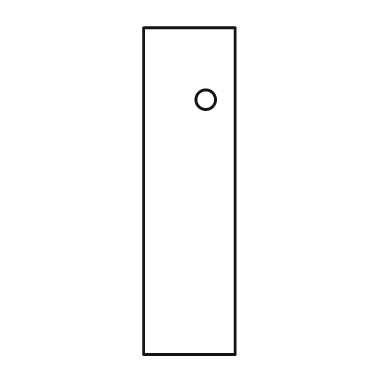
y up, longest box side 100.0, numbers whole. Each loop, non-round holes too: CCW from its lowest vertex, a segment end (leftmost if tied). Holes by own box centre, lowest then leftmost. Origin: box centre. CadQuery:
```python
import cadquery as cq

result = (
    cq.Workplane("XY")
    .moveTo(-14.0, -50.0)
    .lineTo(14.0, -50.0)
    .lineTo(14.0, 50.0)
    .lineTo(-14.0, 50.0)
    .close()
    .moveTo(5.0, 28.0)
    .circle(3.0)
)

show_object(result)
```